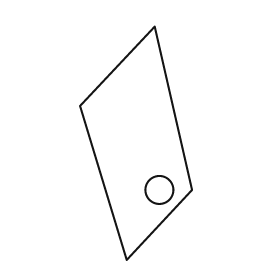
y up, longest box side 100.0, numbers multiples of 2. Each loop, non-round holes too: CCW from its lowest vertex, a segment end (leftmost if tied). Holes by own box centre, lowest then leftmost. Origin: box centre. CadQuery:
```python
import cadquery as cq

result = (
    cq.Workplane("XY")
    .moveTo(-4.0, -50.0)
    .lineTo(24.0, -20.0)
    .lineTo(8.0, 50.0)
    .lineTo(-24.0, 16.0)
    .close()
    .moveTo(10.0, -20.0)
    .circle(6.0)
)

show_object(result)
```